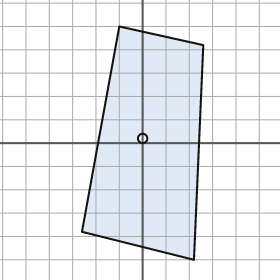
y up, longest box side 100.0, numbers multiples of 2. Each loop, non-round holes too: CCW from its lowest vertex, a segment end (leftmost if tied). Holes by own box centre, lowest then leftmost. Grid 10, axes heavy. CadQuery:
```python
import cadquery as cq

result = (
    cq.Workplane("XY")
    .moveTo(22.0, -50.0)
    .lineTo(26.0, 42.0)
    .lineTo(-10.0, 50.0)
    .lineTo(-26.0, -38.0)
    .close()
    .moveTo(0.0, 2.0)
    .circle(2.0)
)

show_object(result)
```